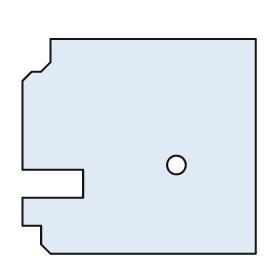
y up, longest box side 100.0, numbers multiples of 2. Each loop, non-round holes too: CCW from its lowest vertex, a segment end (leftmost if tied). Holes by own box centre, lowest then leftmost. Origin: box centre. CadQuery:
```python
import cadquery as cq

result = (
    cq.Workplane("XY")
    .moveTo(-38.0, -46.0)
    .lineTo(50.0, -46.0)
    .lineTo(50.0, 46.0)
    .lineTo(-38.0, 46.0)
    .lineTo(-38.0, 36.0)
    .lineTo(-42.0, 32.0)
    .lineTo(-46.0, 32.0)
    .lineTo(-50.0, 28.0)
    .lineTo(-50.0, -10.0)
    .lineTo(-24.0, -10.0)
    .lineTo(-24.0, -22.0)
    .lineTo(-50.0, -22.0)
    .lineTo(-50.0, -34.0)
    .lineTo(-42.0, -34.0)
    .lineTo(-42.0, -42.0)
    .close()
    .moveTo(16.0, -8.0)
    .circle(4.0)
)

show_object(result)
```